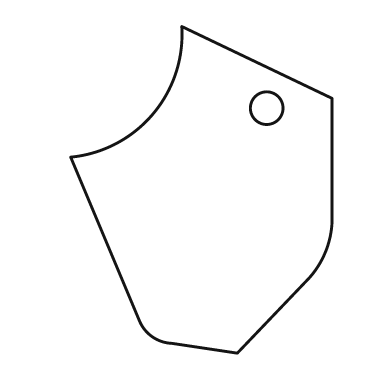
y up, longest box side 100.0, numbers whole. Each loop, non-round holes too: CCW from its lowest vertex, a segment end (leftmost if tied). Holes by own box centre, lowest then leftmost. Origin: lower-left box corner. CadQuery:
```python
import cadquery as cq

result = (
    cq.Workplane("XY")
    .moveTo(51.0, 0.0)
    .lineTo(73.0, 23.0)
    .threePointArc((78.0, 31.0), (80.0, 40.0))
    .lineTo(80.0, 78.0)
    .lineTo(34.0, 100.0)
    .threePointArc((25.0, 73.0), (0.0, 60.0))
    .lineTo(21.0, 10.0)
    .threePointArc((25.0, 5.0), (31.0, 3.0))
    .close()
    .moveTo(60.0, 75.0)
    .circle(5.0)
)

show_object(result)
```